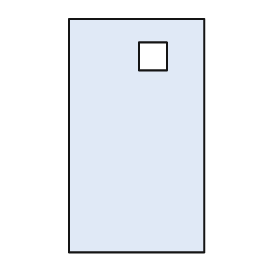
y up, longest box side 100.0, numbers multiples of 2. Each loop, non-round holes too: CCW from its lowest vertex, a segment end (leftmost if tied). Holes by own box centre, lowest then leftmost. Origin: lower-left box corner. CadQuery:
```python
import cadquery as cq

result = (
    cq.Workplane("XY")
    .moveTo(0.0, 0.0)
    .lineTo(58.0, 0.0)
    .lineTo(58.0, 100.0)
    .lineTo(0.0, 100.0)
    .close()
    .moveTo(30.0, 78.0)
    .lineTo(42.0, 78.0)
    .lineTo(42.0, 90.0)
    .lineTo(30.0, 90.0)
    .close()
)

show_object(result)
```